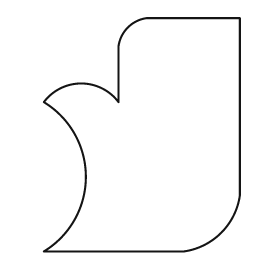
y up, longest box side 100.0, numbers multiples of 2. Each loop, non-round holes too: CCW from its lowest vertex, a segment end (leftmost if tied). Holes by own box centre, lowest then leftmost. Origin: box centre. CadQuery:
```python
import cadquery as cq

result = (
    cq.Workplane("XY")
    .moveTo(-42.0, -50.0)
    .lineTo(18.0, -50.0)
    .threePointArc((34.0, -42.0), (42.0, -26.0))
    .lineTo(42.0, 50.0)
    .lineTo(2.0, 50.0)
    .threePointArc((-6.0, 46.0), (-10.0, 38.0))
    .lineTo(-10.0, 14.0)
    .threePointArc((-26.0, 22.0), (-42.0, 14.0))
    .threePointArc((-24.0, -18.0), (-42.0, -50.0))
    .close()
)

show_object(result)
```